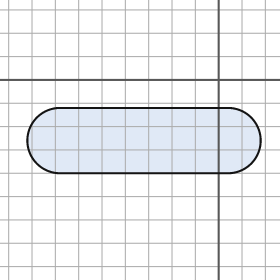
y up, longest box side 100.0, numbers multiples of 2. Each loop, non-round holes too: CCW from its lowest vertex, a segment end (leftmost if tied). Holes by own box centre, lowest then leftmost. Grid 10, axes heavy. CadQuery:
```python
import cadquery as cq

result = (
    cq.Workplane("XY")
    .moveTo(-68.0, -40.0)
    .lineTo(4.0, -40.0)
    .threePointArc((18.0, -26.0), (4.0, -12.0))
    .lineTo(-68.0, -12.0)
    .threePointArc((-82.0, -26.0), (-68.0, -40.0))
    .close()
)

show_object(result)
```